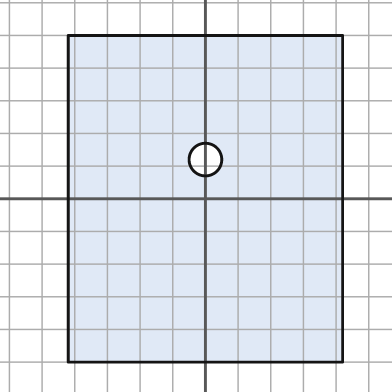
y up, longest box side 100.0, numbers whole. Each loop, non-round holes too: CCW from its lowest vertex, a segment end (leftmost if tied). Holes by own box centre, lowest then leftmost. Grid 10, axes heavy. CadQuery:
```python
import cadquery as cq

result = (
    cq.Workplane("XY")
    .moveTo(-42.0, -50.0)
    .lineTo(42.0, -50.0)
    .lineTo(42.0, 50.0)
    .lineTo(-42.0, 50.0)
    .close()
    .moveTo(0.0, 12.0)
    .circle(5.0)
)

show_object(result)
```